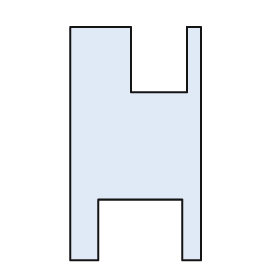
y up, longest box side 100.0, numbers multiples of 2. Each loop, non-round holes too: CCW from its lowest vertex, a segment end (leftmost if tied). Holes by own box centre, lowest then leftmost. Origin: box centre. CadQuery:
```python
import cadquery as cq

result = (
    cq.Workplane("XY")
    .moveTo(-28.0, -50.0)
    .lineTo(-16.0, -50.0)
    .lineTo(-16.0, -24.0)
    .lineTo(20.0, -24.0)
    .lineTo(20.0, -50.0)
    .lineTo(28.0, -50.0)
    .lineTo(28.0, 50.0)
    .lineTo(22.0, 50.0)
    .lineTo(22.0, 22.0)
    .lineTo(-2.0, 22.0)
    .lineTo(-2.0, 50.0)
    .lineTo(-28.0, 50.0)
    .close()
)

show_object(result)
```